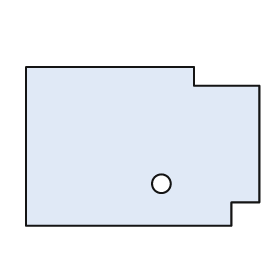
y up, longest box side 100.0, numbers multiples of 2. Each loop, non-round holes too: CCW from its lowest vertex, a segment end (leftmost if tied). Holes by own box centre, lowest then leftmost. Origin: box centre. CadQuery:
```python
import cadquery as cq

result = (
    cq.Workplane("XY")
    .moveTo(-50.0, -34.0)
    .lineTo(38.0, -34.0)
    .lineTo(38.0, -24.0)
    .lineTo(50.0, -24.0)
    .lineTo(50.0, 26.0)
    .lineTo(22.0, 26.0)
    .lineTo(22.0, 34.0)
    .lineTo(-50.0, 34.0)
    .close()
    .moveTo(8.0, -16.0)
    .circle(4.0)
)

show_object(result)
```